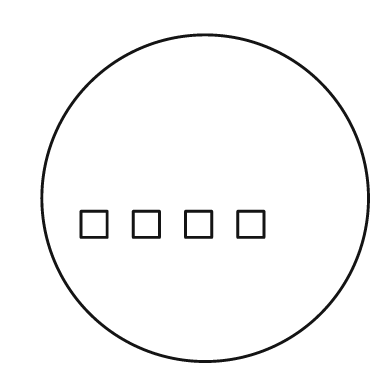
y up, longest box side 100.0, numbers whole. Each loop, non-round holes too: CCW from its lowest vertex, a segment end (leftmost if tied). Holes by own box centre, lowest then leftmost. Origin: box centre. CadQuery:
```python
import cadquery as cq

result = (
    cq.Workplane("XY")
    .moveTo(0.0, 0.0)
    .circle(50.0)
    .moveTo(-38.0, -12.0)
    .lineTo(-30.0, -12.0)
    .lineTo(-30.0, -4.0)
    .lineTo(-38.0, -4.0)
    .close()
    .moveTo(-22.0, -12.0)
    .lineTo(-14.0, -12.0)
    .lineTo(-14.0, -4.0)
    .lineTo(-22.0, -4.0)
    .close()
    .moveTo(-6.0, -12.0)
    .lineTo(2.0, -12.0)
    .lineTo(2.0, -4.0)
    .lineTo(-6.0, -4.0)
    .close()
    .moveTo(10.0, -12.0)
    .lineTo(18.0, -12.0)
    .lineTo(18.0, -4.0)
    .lineTo(10.0, -4.0)
    .close()
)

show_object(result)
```